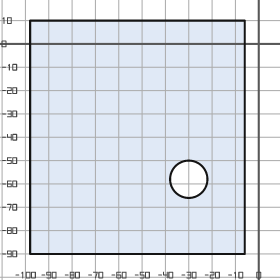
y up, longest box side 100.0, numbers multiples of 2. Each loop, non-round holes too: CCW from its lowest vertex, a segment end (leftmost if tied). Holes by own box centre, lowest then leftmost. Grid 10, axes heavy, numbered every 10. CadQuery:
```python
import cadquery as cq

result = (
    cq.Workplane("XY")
    .moveTo(-98.0, -90.0)
    .lineTo(-6.0, -90.0)
    .lineTo(-6.0, 10.0)
    .lineTo(-98.0, 10.0)
    .close()
    .moveTo(-30.0, -58.0)
    .circle(8.0)
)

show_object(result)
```